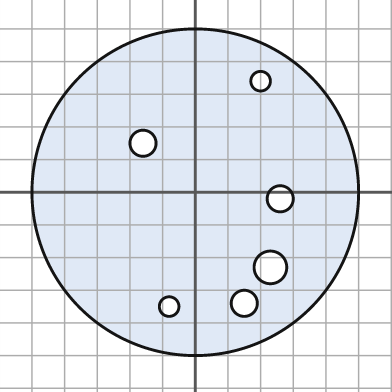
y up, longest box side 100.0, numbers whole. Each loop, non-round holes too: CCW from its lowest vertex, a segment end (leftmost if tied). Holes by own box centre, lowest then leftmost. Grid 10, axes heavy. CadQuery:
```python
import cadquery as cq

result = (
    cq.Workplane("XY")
    .moveTo(0.0, 0.0)
    .circle(50.0)
    .moveTo(-8.0, -35.0)
    .circle(3.0)
    .moveTo(15.0, -34.0)
    .circle(4.0)
    .moveTo(23.0, -23.0)
    .circle(5.0)
    .moveTo(26.0, -2.0)
    .circle(4.0)
    .moveTo(-16.0, 15.0)
    .circle(4.0)
    .moveTo(20.0, 34.0)
    .circle(3.0)
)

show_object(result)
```